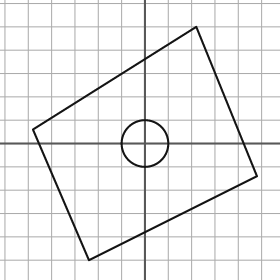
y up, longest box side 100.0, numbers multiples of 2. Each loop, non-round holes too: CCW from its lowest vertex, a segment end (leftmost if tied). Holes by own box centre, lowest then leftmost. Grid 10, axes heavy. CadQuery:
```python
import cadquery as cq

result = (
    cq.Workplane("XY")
    .moveTo(-24.0, -50.0)
    .lineTo(48.0, -14.0)
    .lineTo(22.0, 50.0)
    .lineTo(-48.0, 6.0)
    .close()
    .moveTo(0.0, 0.0)
    .circle(10.0)
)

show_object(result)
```